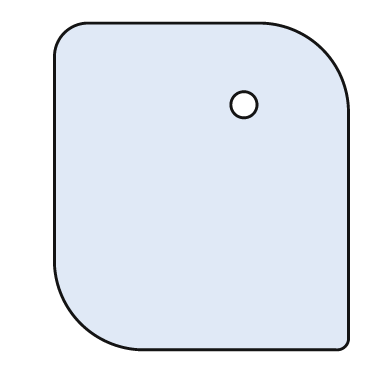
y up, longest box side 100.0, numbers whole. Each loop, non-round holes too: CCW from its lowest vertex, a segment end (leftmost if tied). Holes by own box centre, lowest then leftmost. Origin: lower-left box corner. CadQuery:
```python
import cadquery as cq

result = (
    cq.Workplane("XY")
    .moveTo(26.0, 0.0)
    .lineTo(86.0, 0.0)
    .threePointArc((89.0, 1.0), (90.0, 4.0))
    .lineTo(90.0, 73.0)
    .threePointArc((82.0, 92.0), (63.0, 100.0))
    .lineTo(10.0, 100.0)
    .threePointArc((3.0, 97.0), (0.0, 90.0))
    .lineTo(0.0, 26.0)
    .threePointArc((8.0, 8.0), (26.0, 0.0))
    .close()
    .moveTo(58.0, 75.0)
    .circle(4.0)
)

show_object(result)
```